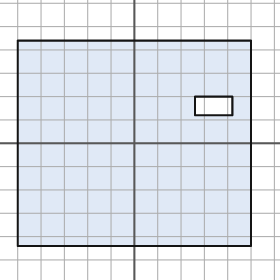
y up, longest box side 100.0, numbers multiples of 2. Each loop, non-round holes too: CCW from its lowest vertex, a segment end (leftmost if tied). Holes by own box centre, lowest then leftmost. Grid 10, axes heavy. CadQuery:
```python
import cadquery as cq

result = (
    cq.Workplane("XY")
    .moveTo(-50.0, -44.0)
    .lineTo(50.0, -44.0)
    .lineTo(50.0, 44.0)
    .lineTo(-50.0, 44.0)
    .close()
    .moveTo(26.0, 12.0)
    .lineTo(42.0, 12.0)
    .lineTo(42.0, 20.0)
    .lineTo(26.0, 20.0)
    .close()
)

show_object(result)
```